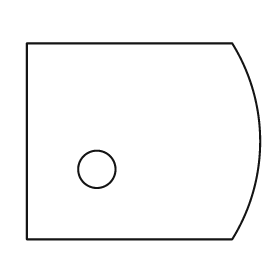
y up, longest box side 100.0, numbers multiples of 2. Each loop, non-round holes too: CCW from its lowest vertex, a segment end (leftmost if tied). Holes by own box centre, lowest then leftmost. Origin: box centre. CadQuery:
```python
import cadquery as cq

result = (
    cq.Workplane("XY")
    .moveTo(-50.0, -42.0)
    .lineTo(38.0, -42.0)
    .threePointArc((50.0, 0.0), (38.0, 42.0))
    .lineTo(-50.0, 42.0)
    .close()
    .moveTo(-20.0, -12.0)
    .circle(8.0)
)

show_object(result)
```